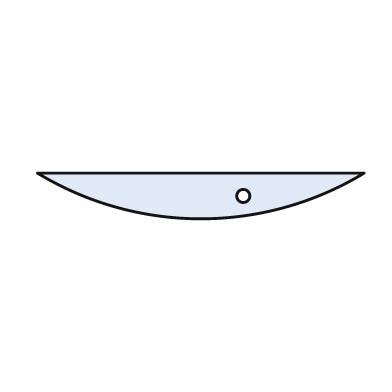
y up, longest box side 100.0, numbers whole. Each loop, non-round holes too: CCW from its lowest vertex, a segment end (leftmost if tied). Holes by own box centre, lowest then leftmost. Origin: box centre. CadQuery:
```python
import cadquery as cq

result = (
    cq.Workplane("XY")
    .moveTo(-50.0, 7.0)
    .threePointArc((0.0, -7.0), (50.0, 7.0))
    .close()
    .moveTo(13.0, 0.0)
    .circle(2.0)
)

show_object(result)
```